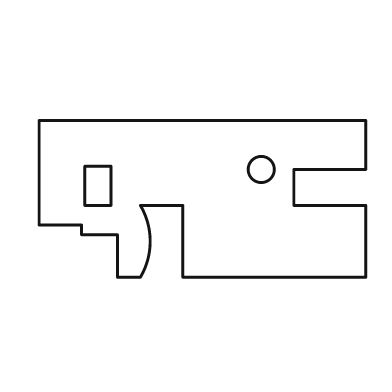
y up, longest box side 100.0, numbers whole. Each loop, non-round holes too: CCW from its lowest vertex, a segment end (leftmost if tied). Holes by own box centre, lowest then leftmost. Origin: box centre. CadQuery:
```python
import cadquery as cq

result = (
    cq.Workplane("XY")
    .moveTo(-26.0, -24.0)
    .lineTo(-19.0, -24.0)
    .threePointArc((-16.0, -13.0), (-19.0, -2.0))
    .lineTo(-6.0, -2.0)
    .lineTo(-6.0, -24.0)
    .lineTo(50.0, -24.0)
    .lineTo(50.0, -2.0)
    .lineTo(28.0, -2.0)
    .lineTo(28.0, 9.0)
    .lineTo(50.0, 9.0)
    .lineTo(50.0, 24.0)
    .lineTo(-50.0, 24.0)
    .lineTo(-50.0, -8.0)
    .lineTo(-37.0, -8.0)
    .lineTo(-37.0, -11.0)
    .lineTo(-26.0, -11.0)
    .close()
    .moveTo(-36.0, -2.0)
    .lineTo(-28.0, -2.0)
    .lineTo(-28.0, 10.0)
    .lineTo(-36.0, 10.0)
    .close()
    .moveTo(18.0, 9.0)
    .circle(4.0)
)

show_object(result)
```